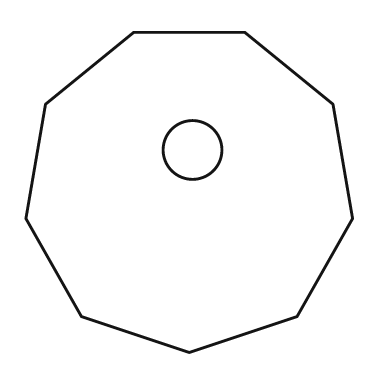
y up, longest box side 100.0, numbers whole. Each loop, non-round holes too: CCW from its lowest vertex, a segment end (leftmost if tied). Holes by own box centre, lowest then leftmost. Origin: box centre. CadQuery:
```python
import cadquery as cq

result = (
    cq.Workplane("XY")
    .moveTo(0.0, -49.0)
    .lineTo(33.0, -38.0)
    .lineTo(50.0, -8.0)
    .lineTo(44.0, 27.0)
    .lineTo(17.0, 49.0)
    .lineTo(-17.0, 49.0)
    .lineTo(-44.0, 27.0)
    .lineTo(-50.0, -8.0)
    .lineTo(-33.0, -38.0)
    .close()
    .moveTo(1.0, 13.0)
    .circle(9.0)
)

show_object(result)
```